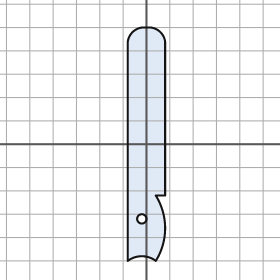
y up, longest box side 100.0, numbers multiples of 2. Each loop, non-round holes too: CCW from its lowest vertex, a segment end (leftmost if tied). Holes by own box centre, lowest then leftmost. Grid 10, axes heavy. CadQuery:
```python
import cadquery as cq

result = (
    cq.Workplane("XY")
    .moveTo(-8.0, -50.0)
    .threePointArc((-2.0, -48.0), (4.0, -50.0))
    .threePointArc((8.0, -36.0), (4.0, -22.0))
    .lineTo(8.0, -22.0)
    .lineTo(8.0, 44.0)
    .threePointArc((6.0, 48.0), (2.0, 50.0))
    .lineTo(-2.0, 50.0)
    .threePointArc((-6.0, 48.0), (-8.0, 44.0))
    .close()
    .moveTo(-2.0, -32.0)
    .circle(2.0)
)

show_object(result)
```